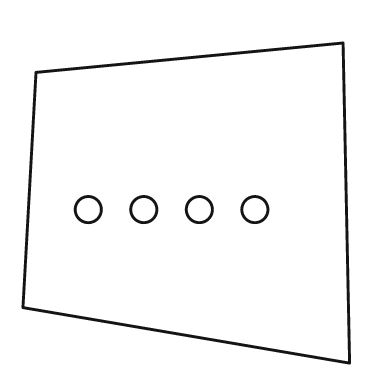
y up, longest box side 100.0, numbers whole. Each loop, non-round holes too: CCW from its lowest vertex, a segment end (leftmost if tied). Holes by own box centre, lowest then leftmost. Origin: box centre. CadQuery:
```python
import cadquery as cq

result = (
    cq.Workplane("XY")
    .moveTo(50.0, -49.0)
    .lineTo(48.0, 49.0)
    .lineTo(-46.0, 40.0)
    .lineTo(-50.0, -32.0)
    .close()
    .moveTo(-30.0, -2.0)
    .circle(4.0)
    .moveTo(-13.0, -2.0)
    .circle(4.0)
    .moveTo(4.0, -2.0)
    .circle(4.0)
    .moveTo(21.0, -2.0)
    .circle(4.0)
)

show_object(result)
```